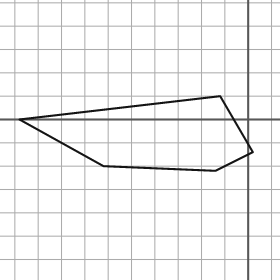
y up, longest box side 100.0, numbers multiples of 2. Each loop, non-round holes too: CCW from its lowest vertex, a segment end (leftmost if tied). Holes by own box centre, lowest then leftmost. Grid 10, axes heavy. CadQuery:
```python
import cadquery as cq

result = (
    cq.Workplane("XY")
    .moveTo(-14.0, -22.0)
    .lineTo(2.0, -14.0)
    .lineTo(-12.0, 10.0)
    .lineTo(-98.0, 0.0)
    .lineTo(-62.0, -20.0)
    .close()
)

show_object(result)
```